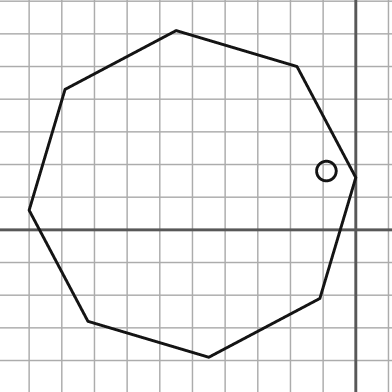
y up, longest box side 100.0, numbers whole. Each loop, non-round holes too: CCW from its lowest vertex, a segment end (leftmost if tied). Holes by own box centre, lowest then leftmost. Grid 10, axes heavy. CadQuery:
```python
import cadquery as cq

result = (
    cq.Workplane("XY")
    .moveTo(-45.0, -39.0)
    .lineTo(-11.0, -21.0)
    .lineTo(0.0, 16.0)
    .lineTo(-18.0, 50.0)
    .lineTo(-55.0, 61.0)
    .lineTo(-89.0, 43.0)
    .lineTo(-100.0, 6.0)
    .lineTo(-82.0, -28.0)
    .close()
    .moveTo(-9.0, 18.0)
    .circle(3.0)
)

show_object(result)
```